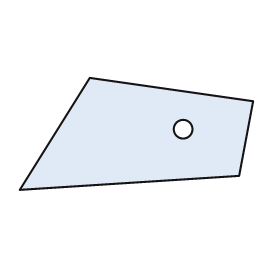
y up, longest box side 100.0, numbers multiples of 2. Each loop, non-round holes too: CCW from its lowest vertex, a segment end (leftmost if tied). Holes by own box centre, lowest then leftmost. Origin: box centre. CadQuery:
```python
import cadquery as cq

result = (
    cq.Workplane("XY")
    .moveTo(-50.0, -24.0)
    .lineTo(44.0, -18.0)
    .lineTo(50.0, 14.0)
    .lineTo(-20.0, 24.0)
    .close()
    .moveTo(20.0, 2.0)
    .circle(4.0)
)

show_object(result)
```